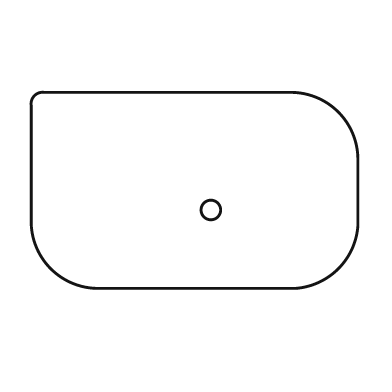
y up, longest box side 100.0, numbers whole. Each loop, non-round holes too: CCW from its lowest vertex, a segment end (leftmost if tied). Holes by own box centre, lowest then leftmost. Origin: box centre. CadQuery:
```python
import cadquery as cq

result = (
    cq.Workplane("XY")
    .moveTo(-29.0, -30.0)
    .lineTo(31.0, -30.0)
    .threePointArc((44.0, -24.0), (50.0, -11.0))
    .lineTo(50.0, 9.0)
    .threePointArc((44.0, 24.0), (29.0, 30.0))
    .lineTo(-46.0, 30.0)
    .threePointArc((-49.0, 29.0), (-50.0, 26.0))
    .lineTo(-50.0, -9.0)
    .threePointArc((-44.0, -24.0), (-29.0, -30.0))
    .close()
    .moveTo(5.0, -6.0)
    .circle(3.0)
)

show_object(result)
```